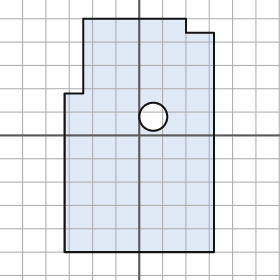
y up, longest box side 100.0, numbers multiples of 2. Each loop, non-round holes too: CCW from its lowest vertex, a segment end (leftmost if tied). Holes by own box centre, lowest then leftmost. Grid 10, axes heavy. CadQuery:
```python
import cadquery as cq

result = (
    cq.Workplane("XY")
    .moveTo(-32.0, -50.0)
    .lineTo(32.0, -50.0)
    .lineTo(32.0, 44.0)
    .lineTo(20.0, 44.0)
    .lineTo(20.0, 50.0)
    .lineTo(-24.0, 50.0)
    .lineTo(-24.0, 18.0)
    .lineTo(-32.0, 18.0)
    .close()
    .moveTo(6.0, 8.0)
    .circle(6.0)
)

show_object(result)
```